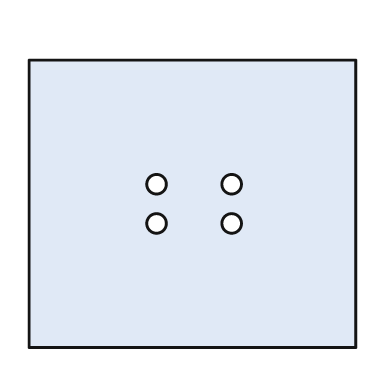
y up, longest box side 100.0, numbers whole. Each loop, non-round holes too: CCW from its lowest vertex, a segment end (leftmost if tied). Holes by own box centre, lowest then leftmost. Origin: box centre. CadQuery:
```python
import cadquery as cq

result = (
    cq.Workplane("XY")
    .moveTo(-50.0, -44.0)
    .lineTo(50.0, -44.0)
    .lineTo(50.0, 44.0)
    .lineTo(-50.0, 44.0)
    .close()
    .moveTo(-11.0, -6.0)
    .circle(3.0)
    .moveTo(12.0, -6.0)
    .circle(3.0)
    .moveTo(-11.0, 6.0)
    .circle(3.0)
    .moveTo(12.0, 6.0)
    .circle(3.0)
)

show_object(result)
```